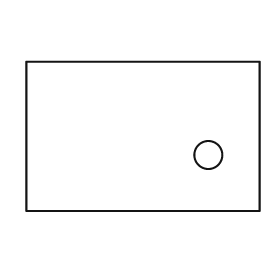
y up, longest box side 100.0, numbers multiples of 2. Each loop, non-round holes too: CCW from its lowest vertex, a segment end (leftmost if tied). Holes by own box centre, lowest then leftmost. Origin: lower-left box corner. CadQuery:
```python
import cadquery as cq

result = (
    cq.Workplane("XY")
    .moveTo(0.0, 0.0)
    .lineTo(100.0, 0.0)
    .lineTo(100.0, 64.0)
    .lineTo(0.0, 64.0)
    .close()
    .moveTo(78.0, 24.0)
    .circle(6.0)
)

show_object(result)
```